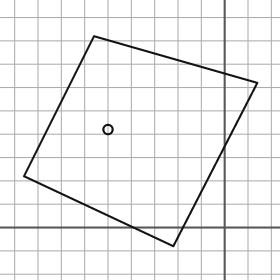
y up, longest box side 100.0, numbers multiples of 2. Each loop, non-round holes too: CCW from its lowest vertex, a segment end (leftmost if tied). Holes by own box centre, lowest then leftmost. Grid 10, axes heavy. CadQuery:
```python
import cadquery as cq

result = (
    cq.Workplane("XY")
    .moveTo(-22.0, -8.0)
    .lineTo(14.0, 62.0)
    .lineTo(-56.0, 82.0)
    .lineTo(-86.0, 22.0)
    .close()
    .moveTo(-50.0, 42.0)
    .circle(2.0)
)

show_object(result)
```